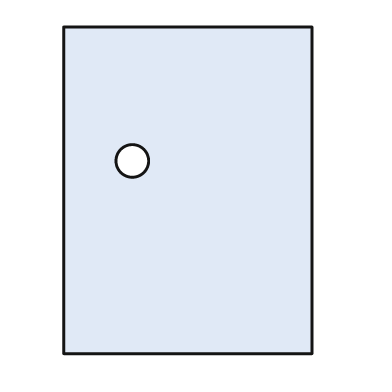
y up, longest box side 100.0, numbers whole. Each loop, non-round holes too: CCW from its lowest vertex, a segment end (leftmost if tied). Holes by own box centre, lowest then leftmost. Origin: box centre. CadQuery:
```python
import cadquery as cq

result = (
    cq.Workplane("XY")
    .moveTo(-38.0, -50.0)
    .lineTo(38.0, -50.0)
    .lineTo(38.0, 50.0)
    .lineTo(-38.0, 50.0)
    .close()
    .moveTo(-17.0, 9.0)
    .circle(5.0)
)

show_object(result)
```